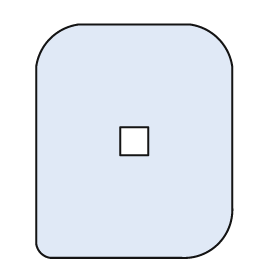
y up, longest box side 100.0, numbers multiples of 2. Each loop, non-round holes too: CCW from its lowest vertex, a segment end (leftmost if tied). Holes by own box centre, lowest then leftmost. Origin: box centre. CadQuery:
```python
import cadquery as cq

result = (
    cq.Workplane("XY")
    .moveTo(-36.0, -50.0)
    .lineTo(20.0, -50.0)
    .threePointArc((36.0, -44.0), (42.0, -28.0))
    .lineTo(42.0, 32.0)
    .threePointArc((36.0, 44.0), (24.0, 50.0))
    .lineTo(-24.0, 50.0)
    .threePointArc((-36.0, 44.0), (-42.0, 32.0))
    .lineTo(-42.0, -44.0)
    .threePointArc((-40.0, -48.0), (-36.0, -50.0))
    .close()
    .moveTo(-6.0, -6.0)
    .lineTo(6.0, -6.0)
    .lineTo(6.0, 6.0)
    .lineTo(-6.0, 6.0)
    .close()
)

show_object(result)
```